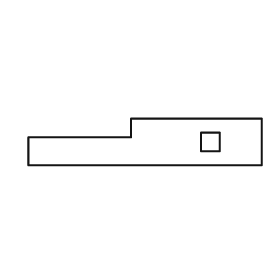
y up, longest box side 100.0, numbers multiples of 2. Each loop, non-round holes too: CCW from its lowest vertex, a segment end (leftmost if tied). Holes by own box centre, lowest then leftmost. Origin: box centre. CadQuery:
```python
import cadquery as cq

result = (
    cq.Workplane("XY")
    .moveTo(-50.0, -10.0)
    .lineTo(50.0, -10.0)
    .lineTo(50.0, 10.0)
    .lineTo(-6.0, 10.0)
    .lineTo(-6.0, 2.0)
    .lineTo(-50.0, 2.0)
    .close()
    .moveTo(24.0, -4.0)
    .lineTo(32.0, -4.0)
    .lineTo(32.0, 4.0)
    .lineTo(24.0, 4.0)
    .close()
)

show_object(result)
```